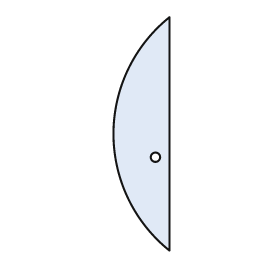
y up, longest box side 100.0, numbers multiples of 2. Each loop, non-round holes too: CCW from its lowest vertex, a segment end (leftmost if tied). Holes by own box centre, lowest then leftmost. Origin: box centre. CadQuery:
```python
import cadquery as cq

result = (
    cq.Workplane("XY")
    .moveTo(12.0, -50.0)
    .lineTo(12.0, 50.0)
    .threePointArc((-12.0, 0.0), (12.0, -50.0))
    .close()
    .moveTo(6.0, -10.0)
    .circle(2.0)
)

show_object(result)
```